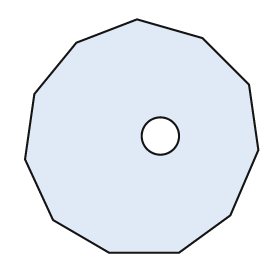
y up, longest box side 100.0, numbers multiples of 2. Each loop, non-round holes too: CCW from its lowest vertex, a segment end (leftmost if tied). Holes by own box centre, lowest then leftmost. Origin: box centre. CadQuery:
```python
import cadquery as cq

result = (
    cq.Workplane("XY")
    .moveTo(-14.0, -50.0)
    .lineTo(16.0, -50.0)
    .lineTo(38.0, -34.0)
    .lineTo(50.0, -6.0)
    .lineTo(46.0, 22.0)
    .lineTo(26.0, 42.0)
    .lineTo(-2.0, 50.0)
    .lineTo(-28.0, 40.0)
    .lineTo(-46.0, 18.0)
    .lineTo(-50.0, -10.0)
    .lineTo(-38.0, -36.0)
    .close()
    .moveTo(8.0, 0.0)
    .circle(8.0)
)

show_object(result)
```